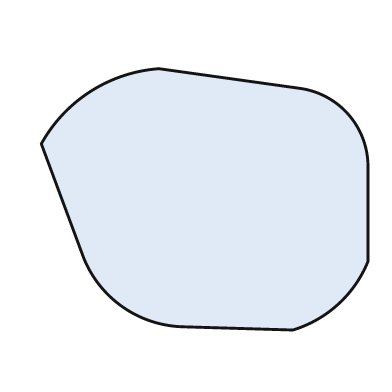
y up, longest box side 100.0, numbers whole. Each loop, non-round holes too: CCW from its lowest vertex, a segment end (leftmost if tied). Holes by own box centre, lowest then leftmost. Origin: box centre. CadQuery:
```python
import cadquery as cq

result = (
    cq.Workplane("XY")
    .moveTo(27.0, -40.0)
    .threePointArc((41.0, -32.0), (50.0, -19.0))
    .lineTo(50.0, 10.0)
    .threePointArc((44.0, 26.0), (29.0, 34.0))
    .lineTo(-14.0, 40.0)
    .threePointArc((-35.0, 33.0), (-50.0, 17.0))
    .lineTo(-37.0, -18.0)
    .threePointArc((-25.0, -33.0), (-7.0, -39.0))
    .close()
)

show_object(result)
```